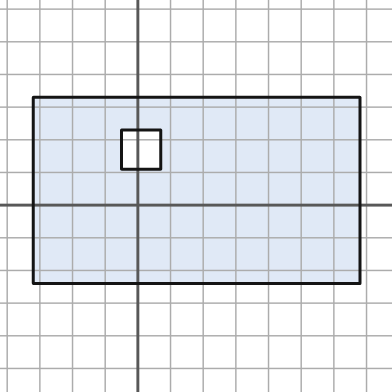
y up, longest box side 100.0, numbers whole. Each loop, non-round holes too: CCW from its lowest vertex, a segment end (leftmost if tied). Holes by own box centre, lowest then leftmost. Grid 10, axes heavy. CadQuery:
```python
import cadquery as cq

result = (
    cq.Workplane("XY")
    .moveTo(-32.0, -24.0)
    .lineTo(68.0, -24.0)
    .lineTo(68.0, 33.0)
    .lineTo(-32.0, 33.0)
    .close()
    .moveTo(-5.0, 11.0)
    .lineTo(7.0, 11.0)
    .lineTo(7.0, 23.0)
    .lineTo(-5.0, 23.0)
    .close()
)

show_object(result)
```